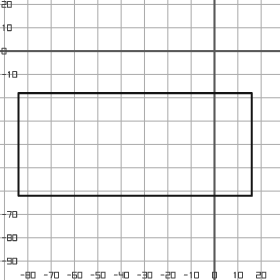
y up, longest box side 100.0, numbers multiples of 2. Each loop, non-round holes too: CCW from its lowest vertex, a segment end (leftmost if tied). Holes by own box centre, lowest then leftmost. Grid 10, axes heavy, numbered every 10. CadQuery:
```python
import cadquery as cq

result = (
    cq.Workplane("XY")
    .moveTo(-84.0, -62.0)
    .lineTo(16.0, -62.0)
    .lineTo(16.0, -18.0)
    .lineTo(-84.0, -18.0)
    .close()
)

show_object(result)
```